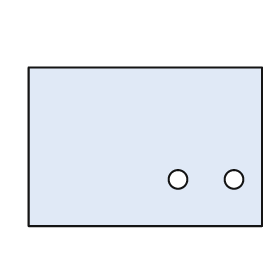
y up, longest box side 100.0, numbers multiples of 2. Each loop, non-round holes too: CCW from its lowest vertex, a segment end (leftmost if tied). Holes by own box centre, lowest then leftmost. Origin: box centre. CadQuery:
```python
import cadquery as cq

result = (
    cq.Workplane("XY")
    .moveTo(-50.0, -34.0)
    .lineTo(50.0, -34.0)
    .lineTo(50.0, 34.0)
    .lineTo(-50.0, 34.0)
    .close()
    .moveTo(14.0, -14.0)
    .circle(4.0)
    .moveTo(38.0, -14.0)
    .circle(4.0)
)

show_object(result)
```